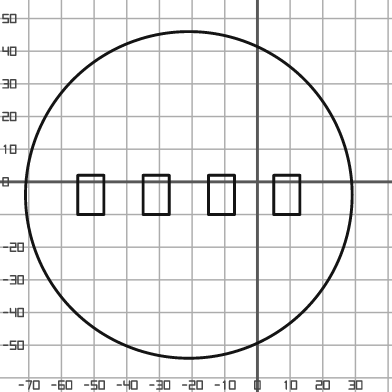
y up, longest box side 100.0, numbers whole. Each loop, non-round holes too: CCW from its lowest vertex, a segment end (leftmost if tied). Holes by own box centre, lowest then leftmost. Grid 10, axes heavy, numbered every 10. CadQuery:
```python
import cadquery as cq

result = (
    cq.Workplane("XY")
    .moveTo(-21.0, -4.0)
    .circle(50.0)
    .moveTo(-55.0, -10.0)
    .lineTo(-47.0, -10.0)
    .lineTo(-47.0, 2.0)
    .lineTo(-55.0, 2.0)
    .close()
    .moveTo(-35.0, -10.0)
    .lineTo(-27.0, -10.0)
    .lineTo(-27.0, 2.0)
    .lineTo(-35.0, 2.0)
    .close()
    .moveTo(-15.0, -10.0)
    .lineTo(-7.0, -10.0)
    .lineTo(-7.0, 2.0)
    .lineTo(-15.0, 2.0)
    .close()
    .moveTo(5.0, -10.0)
    .lineTo(13.0, -10.0)
    .lineTo(13.0, 2.0)
    .lineTo(5.0, 2.0)
    .close()
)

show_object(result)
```